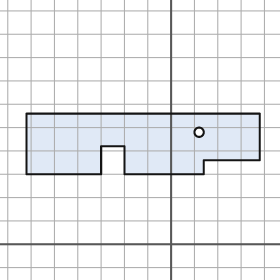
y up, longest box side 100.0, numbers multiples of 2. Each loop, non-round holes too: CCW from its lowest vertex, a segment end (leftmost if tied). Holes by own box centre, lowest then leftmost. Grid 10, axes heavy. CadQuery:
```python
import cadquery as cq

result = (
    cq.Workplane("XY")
    .moveTo(-62.0, 30.0)
    .lineTo(-30.0, 30.0)
    .lineTo(-30.0, 42.0)
    .lineTo(-20.0, 42.0)
    .lineTo(-20.0, 30.0)
    .lineTo(14.0, 30.0)
    .lineTo(14.0, 36.0)
    .lineTo(38.0, 36.0)
    .lineTo(38.0, 56.0)
    .lineTo(-62.0, 56.0)
    .close()
    .moveTo(12.0, 48.0)
    .circle(2.0)
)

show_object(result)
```